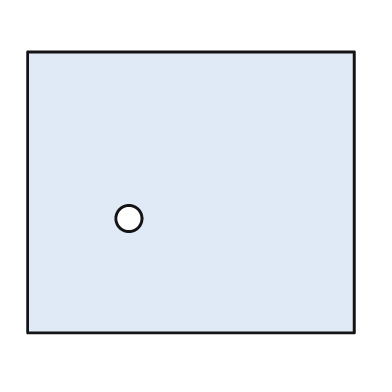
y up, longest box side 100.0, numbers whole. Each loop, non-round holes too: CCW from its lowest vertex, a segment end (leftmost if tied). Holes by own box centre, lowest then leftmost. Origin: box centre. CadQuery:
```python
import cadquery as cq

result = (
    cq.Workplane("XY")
    .moveTo(-50.0, -43.0)
    .lineTo(50.0, -43.0)
    .lineTo(50.0, 43.0)
    .lineTo(-50.0, 43.0)
    .close()
    .moveTo(-19.0, -8.0)
    .circle(4.0)
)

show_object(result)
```